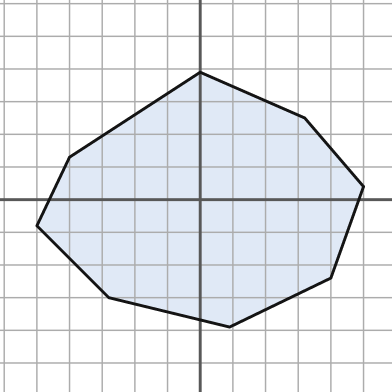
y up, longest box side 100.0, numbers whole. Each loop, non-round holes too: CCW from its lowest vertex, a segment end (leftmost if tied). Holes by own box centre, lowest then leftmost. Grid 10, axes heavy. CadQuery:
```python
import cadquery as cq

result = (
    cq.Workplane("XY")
    .moveTo(9.0, -39.0)
    .lineTo(40.0, -24.0)
    .lineTo(50.0, 4.0)
    .lineTo(32.0, 25.0)
    .lineTo(0.0, 39.0)
    .lineTo(-40.0, 13.0)
    .lineTo(-50.0, -8.0)
    .lineTo(-28.0, -30.0)
    .close()
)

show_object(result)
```